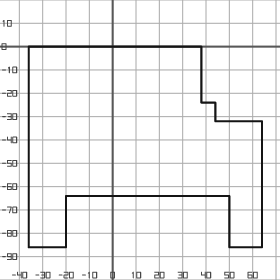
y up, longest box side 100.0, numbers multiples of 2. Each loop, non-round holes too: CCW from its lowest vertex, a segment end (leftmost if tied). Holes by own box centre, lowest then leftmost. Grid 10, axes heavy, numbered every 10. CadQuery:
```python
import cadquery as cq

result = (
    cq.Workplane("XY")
    .moveTo(-36.0, -86.0)
    .lineTo(-20.0, -86.0)
    .lineTo(-20.0, -64.0)
    .lineTo(50.0, -64.0)
    .lineTo(50.0, -86.0)
    .lineTo(64.0, -86.0)
    .lineTo(64.0, -32.0)
    .lineTo(44.0, -32.0)
    .lineTo(44.0, -24.0)
    .lineTo(38.0, -24.0)
    .lineTo(38.0, 0.0)
    .lineTo(-36.0, 0.0)
    .close()
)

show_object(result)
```